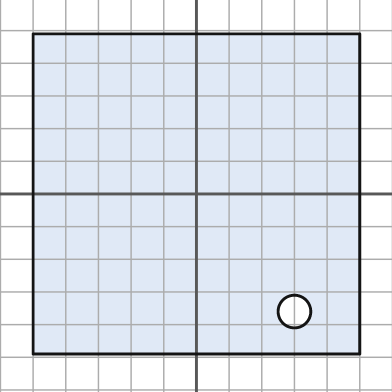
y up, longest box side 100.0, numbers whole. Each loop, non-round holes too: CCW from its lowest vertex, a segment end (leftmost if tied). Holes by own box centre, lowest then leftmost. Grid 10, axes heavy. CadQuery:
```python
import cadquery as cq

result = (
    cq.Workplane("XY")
    .moveTo(-50.0, -49.0)
    .lineTo(50.0, -49.0)
    .lineTo(50.0, 49.0)
    .lineTo(-50.0, 49.0)
    .close()
    .moveTo(30.0, -36.0)
    .circle(5.0)
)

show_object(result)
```